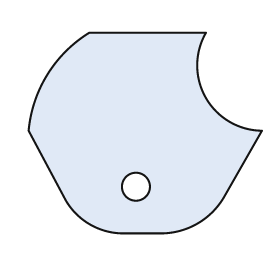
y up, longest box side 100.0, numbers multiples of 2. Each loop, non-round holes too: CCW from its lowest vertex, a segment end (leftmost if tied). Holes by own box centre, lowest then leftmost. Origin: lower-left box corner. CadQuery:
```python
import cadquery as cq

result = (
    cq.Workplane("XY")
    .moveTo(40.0, 0.0)
    .lineTo(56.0, 0.0)
    .threePointArc((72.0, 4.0), (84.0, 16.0))
    .lineTo(100.0, 44.0)
    .threePointArc((76.0, 58.0), (76.0, 86.0))
    .lineTo(26.0, 86.0)
    .threePointArc((8.0, 68.0), (0.0, 44.0))
    .lineTo(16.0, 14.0)
    .threePointArc((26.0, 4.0), (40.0, 0.0))
    .close()
    .moveTo(46.0, 20.0)
    .circle(6.0)
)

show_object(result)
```